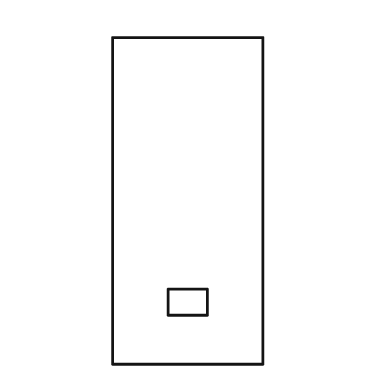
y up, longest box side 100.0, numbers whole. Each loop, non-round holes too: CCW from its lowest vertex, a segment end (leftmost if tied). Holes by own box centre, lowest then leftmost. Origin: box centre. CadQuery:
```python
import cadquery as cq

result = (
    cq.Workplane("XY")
    .moveTo(-23.0, -50.0)
    .lineTo(23.0, -50.0)
    .lineTo(23.0, 50.0)
    .lineTo(-23.0, 50.0)
    .close()
    .moveTo(-6.0, -35.0)
    .lineTo(6.0, -35.0)
    .lineTo(6.0, -27.0)
    .lineTo(-6.0, -27.0)
    .close()
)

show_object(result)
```